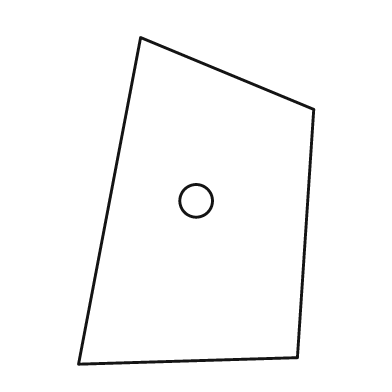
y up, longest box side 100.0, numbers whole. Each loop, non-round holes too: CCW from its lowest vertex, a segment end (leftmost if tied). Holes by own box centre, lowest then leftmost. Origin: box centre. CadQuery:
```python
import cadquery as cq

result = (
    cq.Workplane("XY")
    .moveTo(-36.0, -50.0)
    .lineTo(31.0, -48.0)
    .lineTo(36.0, 28.0)
    .lineTo(-17.0, 50.0)
    .close()
    .moveTo(0.0, 0.0)
    .circle(5.0)
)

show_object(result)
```